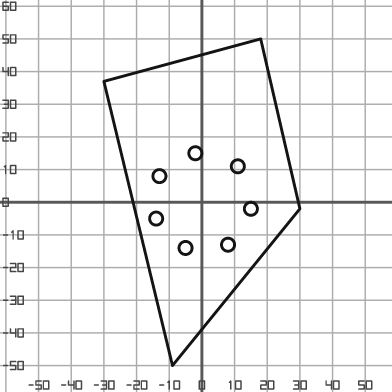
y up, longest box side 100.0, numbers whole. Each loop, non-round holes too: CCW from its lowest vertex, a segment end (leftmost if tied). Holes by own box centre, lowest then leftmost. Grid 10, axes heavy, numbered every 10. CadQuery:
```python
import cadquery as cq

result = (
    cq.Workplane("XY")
    .moveTo(-9.0, -50.0)
    .lineTo(30.0, -2.0)
    .lineTo(18.0, 50.0)
    .lineTo(-30.0, 37.0)
    .close()
    .moveTo(-5.0, -14.0)
    .circle(2.0)
    .moveTo(8.0, -13.0)
    .circle(2.0)
    .moveTo(-14.0, -5.0)
    .circle(2.0)
    .moveTo(15.0, -2.0)
    .circle(2.0)
    .moveTo(-13.0, 8.0)
    .circle(2.0)
    .moveTo(11.0, 11.0)
    .circle(2.0)
    .moveTo(-2.0, 15.0)
    .circle(2.0)
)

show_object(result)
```